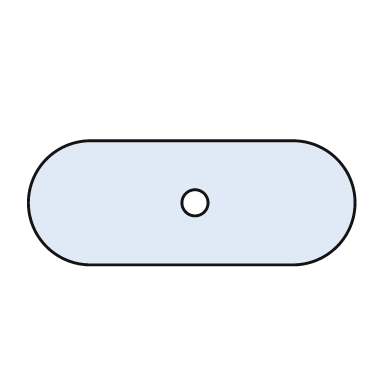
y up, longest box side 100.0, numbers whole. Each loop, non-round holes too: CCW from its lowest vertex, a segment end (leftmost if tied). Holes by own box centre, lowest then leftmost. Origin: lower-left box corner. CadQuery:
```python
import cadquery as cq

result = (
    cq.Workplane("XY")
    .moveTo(19.0, 0.0)
    .lineTo(81.0, 0.0)
    .threePointArc((100.0, 19.0), (81.0, 38.0))
    .lineTo(19.0, 38.0)
    .threePointArc((0.0, 19.0), (19.0, 0.0))
    .close()
    .moveTo(51.0, 19.0)
    .circle(4.0)
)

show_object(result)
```